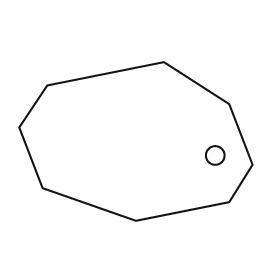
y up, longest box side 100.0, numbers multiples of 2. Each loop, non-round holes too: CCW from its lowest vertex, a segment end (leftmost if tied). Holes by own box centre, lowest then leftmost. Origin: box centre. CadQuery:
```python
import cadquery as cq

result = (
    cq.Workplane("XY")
    .moveTo(0.0, -34.0)
    .lineTo(40.0, -26.0)
    .lineTo(50.0, -10.0)
    .lineTo(40.0, 16.0)
    .lineTo(12.0, 34.0)
    .lineTo(-38.0, 24.0)
    .lineTo(-50.0, 6.0)
    .lineTo(-40.0, -20.0)
    .close()
    .moveTo(34.0, -6.0)
    .circle(4.0)
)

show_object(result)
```